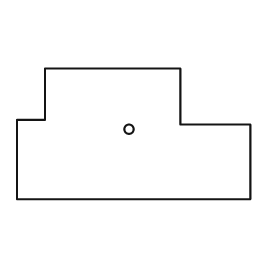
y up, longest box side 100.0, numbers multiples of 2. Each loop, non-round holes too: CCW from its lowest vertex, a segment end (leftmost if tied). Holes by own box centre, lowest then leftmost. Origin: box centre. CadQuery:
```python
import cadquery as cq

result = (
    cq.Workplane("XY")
    .moveTo(-50.0, -28.0)
    .lineTo(50.0, -28.0)
    .lineTo(50.0, 4.0)
    .lineTo(20.0, 4.0)
    .lineTo(20.0, 28.0)
    .lineTo(-38.0, 28.0)
    .lineTo(-38.0, 6.0)
    .lineTo(-50.0, 6.0)
    .close()
    .moveTo(-2.0, 2.0)
    .circle(2.0)
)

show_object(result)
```